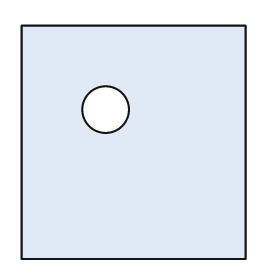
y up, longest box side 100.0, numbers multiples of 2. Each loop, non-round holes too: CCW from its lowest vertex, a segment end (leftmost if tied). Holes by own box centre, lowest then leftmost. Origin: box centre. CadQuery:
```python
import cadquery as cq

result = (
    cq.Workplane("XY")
    .moveTo(-48.0, -50.0)
    .lineTo(48.0, -50.0)
    .lineTo(48.0, 50.0)
    .lineTo(-48.0, 50.0)
    .close()
    .moveTo(-12.0, 14.0)
    .circle(10.0)
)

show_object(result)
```